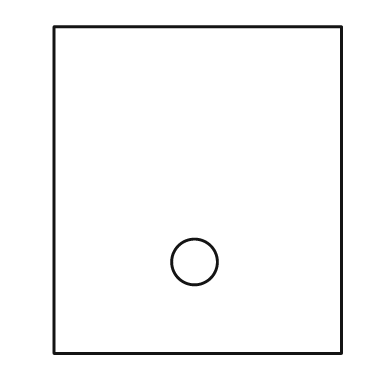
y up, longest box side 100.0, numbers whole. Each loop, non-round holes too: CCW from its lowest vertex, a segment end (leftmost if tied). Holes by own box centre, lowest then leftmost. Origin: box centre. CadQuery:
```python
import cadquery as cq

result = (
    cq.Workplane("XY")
    .moveTo(-44.0, -50.0)
    .lineTo(44.0, -50.0)
    .lineTo(44.0, 50.0)
    .lineTo(-44.0, 50.0)
    .close()
    .moveTo(-1.0, -22.0)
    .circle(7.0)
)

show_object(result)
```